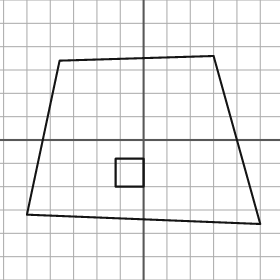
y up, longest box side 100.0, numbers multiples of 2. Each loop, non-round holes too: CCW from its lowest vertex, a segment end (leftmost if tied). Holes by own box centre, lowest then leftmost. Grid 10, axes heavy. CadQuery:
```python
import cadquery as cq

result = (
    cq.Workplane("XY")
    .moveTo(50.0, -36.0)
    .lineTo(30.0, 36.0)
    .lineTo(-36.0, 34.0)
    .lineTo(-50.0, -32.0)
    .close()
    .moveTo(-12.0, -20.0)
    .lineTo(0.0, -20.0)
    .lineTo(0.0, -8.0)
    .lineTo(-12.0, -8.0)
    .close()
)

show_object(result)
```